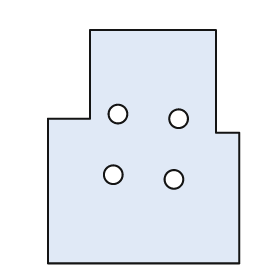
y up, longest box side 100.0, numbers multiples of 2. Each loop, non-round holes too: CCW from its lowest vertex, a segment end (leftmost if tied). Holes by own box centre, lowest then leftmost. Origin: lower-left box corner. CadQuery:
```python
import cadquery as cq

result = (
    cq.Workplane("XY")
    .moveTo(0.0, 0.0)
    .lineTo(82.0, 0.0)
    .lineTo(82.0, 56.0)
    .lineTo(72.0, 56.0)
    .lineTo(72.0, 100.0)
    .lineTo(18.0, 100.0)
    .lineTo(18.0, 62.0)
    .lineTo(0.0, 62.0)
    .close()
    .moveTo(54.0, 36.0)
    .circle(4.0)
    .moveTo(28.0, 38.0)
    .circle(4.0)
    .moveTo(56.0, 62.0)
    .circle(4.0)
    .moveTo(30.0, 64.0)
    .circle(4.0)
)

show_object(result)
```